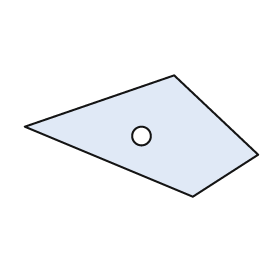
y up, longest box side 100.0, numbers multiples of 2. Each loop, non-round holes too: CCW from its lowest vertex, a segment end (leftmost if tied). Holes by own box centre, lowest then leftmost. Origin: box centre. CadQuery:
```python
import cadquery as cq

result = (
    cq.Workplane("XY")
    .moveTo(22.0, -26.0)
    .lineTo(50.0, -8.0)
    .lineTo(14.0, 26.0)
    .lineTo(-50.0, 4.0)
    .close()
    .moveTo(0.0, 0.0)
    .circle(4.0)
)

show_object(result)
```